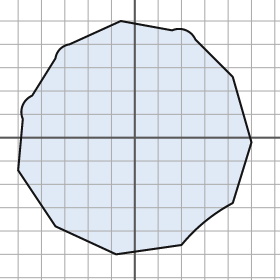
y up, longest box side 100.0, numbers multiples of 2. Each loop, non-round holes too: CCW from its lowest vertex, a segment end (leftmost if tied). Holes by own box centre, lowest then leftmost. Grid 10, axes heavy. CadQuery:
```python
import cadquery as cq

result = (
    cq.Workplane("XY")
    .moveTo(-8.0, -50.0)
    .lineTo(20.0, -46.0)
    .threePointArc((30.0, -36.0), (42.0, -28.0))
    .lineTo(50.0, -2.0)
    .lineTo(42.0, 26.0)
    .lineTo(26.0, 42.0)
    .threePointArc((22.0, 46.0), (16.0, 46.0))
    .lineTo(-6.0, 50.0)
    .lineTo(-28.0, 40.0)
    .threePointArc((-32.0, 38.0), (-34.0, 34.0))
    .lineTo(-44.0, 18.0)
    .threePointArc((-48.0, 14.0), (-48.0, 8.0))
    .lineTo(-50.0, -14.0)
    .lineTo(-34.0, -38.0)
    .close()
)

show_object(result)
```